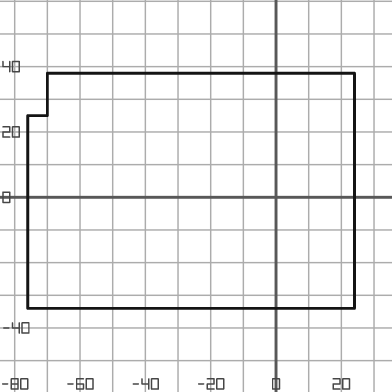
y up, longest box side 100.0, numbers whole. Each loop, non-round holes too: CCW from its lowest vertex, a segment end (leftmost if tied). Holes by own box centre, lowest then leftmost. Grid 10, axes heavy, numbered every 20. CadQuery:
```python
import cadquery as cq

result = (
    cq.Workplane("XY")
    .moveTo(-76.0, -34.0)
    .lineTo(24.0, -34.0)
    .lineTo(24.0, 38.0)
    .lineTo(-70.0, 38.0)
    .lineTo(-70.0, 25.0)
    .lineTo(-76.0, 25.0)
    .close()
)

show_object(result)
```